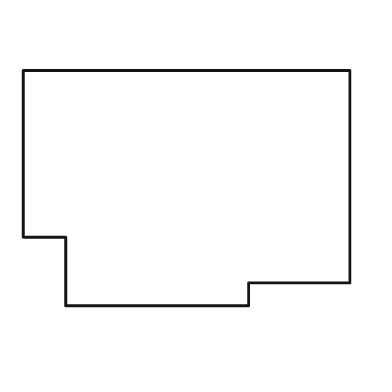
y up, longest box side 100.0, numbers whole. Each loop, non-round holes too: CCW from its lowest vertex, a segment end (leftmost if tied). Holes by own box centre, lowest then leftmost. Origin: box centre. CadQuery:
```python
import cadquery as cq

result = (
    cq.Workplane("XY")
    .moveTo(-37.0, -36.0)
    .lineTo(19.0, -36.0)
    .lineTo(19.0, -29.0)
    .lineTo(50.0, -29.0)
    .lineTo(50.0, 36.0)
    .lineTo(-50.0, 36.0)
    .lineTo(-50.0, -15.0)
    .lineTo(-37.0, -15.0)
    .close()
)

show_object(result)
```